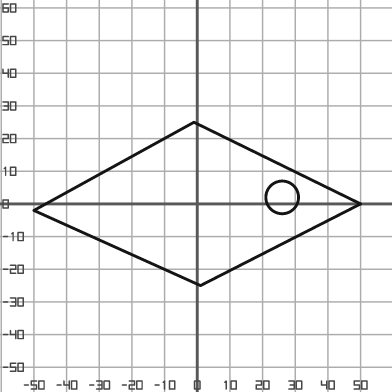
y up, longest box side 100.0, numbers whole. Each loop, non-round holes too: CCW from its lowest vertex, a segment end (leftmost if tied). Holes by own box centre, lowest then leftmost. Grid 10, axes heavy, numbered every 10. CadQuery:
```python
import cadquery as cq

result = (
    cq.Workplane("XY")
    .moveTo(1.0, -25.0)
    .lineTo(50.0, 0.0)
    .lineTo(-1.0, 25.0)
    .lineTo(-50.0, -2.0)
    .close()
    .moveTo(26.0, 2.0)
    .circle(5.0)
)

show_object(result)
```